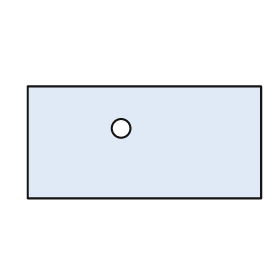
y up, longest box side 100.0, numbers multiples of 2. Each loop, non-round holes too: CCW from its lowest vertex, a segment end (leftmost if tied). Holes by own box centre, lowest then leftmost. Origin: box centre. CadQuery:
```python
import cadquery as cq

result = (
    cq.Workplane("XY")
    .moveTo(-50.0, -24.0)
    .lineTo(50.0, -24.0)
    .lineTo(50.0, 24.0)
    .lineTo(-50.0, 24.0)
    .close()
    .moveTo(-10.0, 6.0)
    .circle(4.0)
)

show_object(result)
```